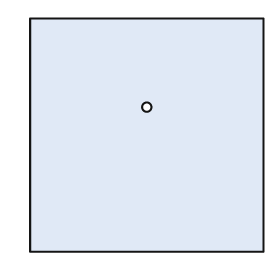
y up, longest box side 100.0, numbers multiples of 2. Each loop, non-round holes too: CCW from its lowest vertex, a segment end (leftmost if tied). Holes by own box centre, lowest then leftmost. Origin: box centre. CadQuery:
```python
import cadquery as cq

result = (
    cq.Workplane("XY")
    .moveTo(-50.0, -50.0)
    .lineTo(50.0, -50.0)
    .lineTo(50.0, 50.0)
    .lineTo(-50.0, 50.0)
    .close()
    .moveTo(0.0, 12.0)
    .circle(2.0)
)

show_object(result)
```